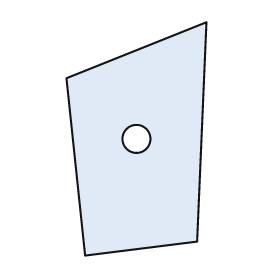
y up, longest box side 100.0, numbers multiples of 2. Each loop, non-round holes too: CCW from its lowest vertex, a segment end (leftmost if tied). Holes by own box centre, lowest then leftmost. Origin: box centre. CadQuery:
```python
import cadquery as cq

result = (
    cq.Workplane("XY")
    .moveTo(-22.0, -50.0)
    .lineTo(26.0, -44.0)
    .lineTo(30.0, 50.0)
    .lineTo(-30.0, 26.0)
    .close()
    .moveTo(0.0, 0.0)
    .circle(6.0)
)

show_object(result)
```